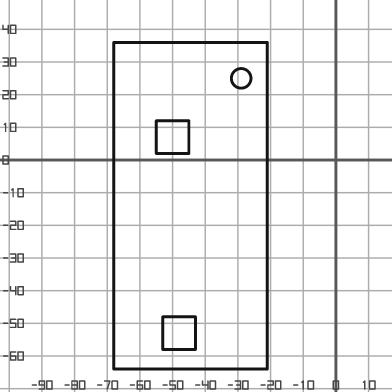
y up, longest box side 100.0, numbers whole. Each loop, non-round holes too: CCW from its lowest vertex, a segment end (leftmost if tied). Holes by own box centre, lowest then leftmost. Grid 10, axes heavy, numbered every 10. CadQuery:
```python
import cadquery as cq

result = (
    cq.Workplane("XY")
    .moveTo(-68.0, -64.0)
    .lineTo(-21.0, -64.0)
    .lineTo(-21.0, 36.0)
    .lineTo(-68.0, 36.0)
    .close()
    .moveTo(-53.0, -58.0)
    .lineTo(-43.0, -58.0)
    .lineTo(-43.0, -48.0)
    .lineTo(-53.0, -48.0)
    .close()
    .moveTo(-55.0, 2.0)
    .lineTo(-45.0, 2.0)
    .lineTo(-45.0, 12.0)
    .lineTo(-55.0, 12.0)
    .close()
    .moveTo(-29.0, 25.0)
    .circle(3.0)
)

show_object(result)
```